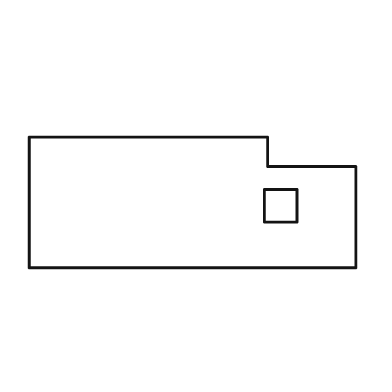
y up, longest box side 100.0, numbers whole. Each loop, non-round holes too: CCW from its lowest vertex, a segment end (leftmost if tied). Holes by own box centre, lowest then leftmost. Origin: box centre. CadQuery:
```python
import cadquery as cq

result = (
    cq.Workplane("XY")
    .moveTo(-50.0, -20.0)
    .lineTo(50.0, -20.0)
    .lineTo(50.0, 11.0)
    .lineTo(23.0, 11.0)
    .lineTo(23.0, 20.0)
    .lineTo(-50.0, 20.0)
    .close()
    .moveTo(22.0, -6.0)
    .lineTo(32.0, -6.0)
    .lineTo(32.0, 4.0)
    .lineTo(22.0, 4.0)
    .close()
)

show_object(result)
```